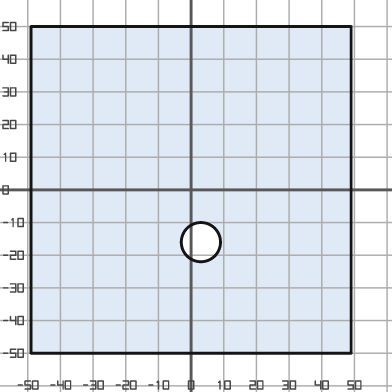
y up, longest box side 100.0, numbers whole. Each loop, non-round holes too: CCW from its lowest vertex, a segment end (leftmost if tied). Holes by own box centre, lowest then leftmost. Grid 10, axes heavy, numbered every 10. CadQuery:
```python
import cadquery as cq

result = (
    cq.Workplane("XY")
    .moveTo(-49.0, -50.0)
    .lineTo(49.0, -50.0)
    .lineTo(49.0, 50.0)
    .lineTo(-49.0, 50.0)
    .close()
    .moveTo(3.0, -16.0)
    .circle(6.0)
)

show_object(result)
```